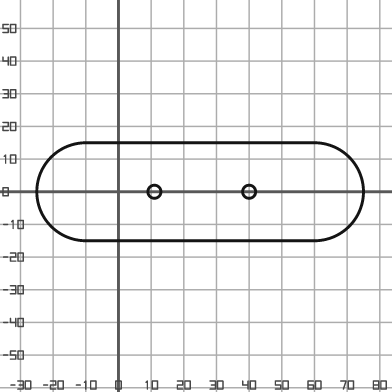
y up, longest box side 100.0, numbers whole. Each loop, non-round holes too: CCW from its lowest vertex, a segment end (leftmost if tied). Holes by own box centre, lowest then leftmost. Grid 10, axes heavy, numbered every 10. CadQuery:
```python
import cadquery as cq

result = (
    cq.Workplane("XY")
    .moveTo(-10.0, -15.0)
    .lineTo(60.0, -15.0)
    .threePointArc((75.0, 0.0), (60.0, 15.0))
    .lineTo(-10.0, 15.0)
    .threePointArc((-25.0, 0.0), (-10.0, -15.0))
    .close()
    .moveTo(11.0, 0.0)
    .circle(2.0)
    .moveTo(40.0, 0.0)
    .circle(2.0)
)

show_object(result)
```